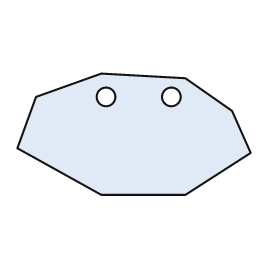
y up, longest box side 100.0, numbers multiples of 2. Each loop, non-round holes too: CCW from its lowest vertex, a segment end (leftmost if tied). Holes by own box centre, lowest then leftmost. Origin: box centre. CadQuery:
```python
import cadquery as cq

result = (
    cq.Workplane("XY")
    .moveTo(-14.0, -26.0)
    .lineTo(22.0, -26.0)
    .lineTo(50.0, -8.0)
    .lineTo(42.0, 10.0)
    .lineTo(22.0, 24.0)
    .lineTo(-14.0, 26.0)
    .lineTo(-42.0, 16.0)
    .lineTo(-50.0, -6.0)
    .close()
    .moveTo(-12.0, 16.0)
    .circle(4.0)
    .moveTo(16.0, 16.0)
    .circle(4.0)
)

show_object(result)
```